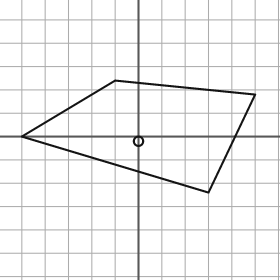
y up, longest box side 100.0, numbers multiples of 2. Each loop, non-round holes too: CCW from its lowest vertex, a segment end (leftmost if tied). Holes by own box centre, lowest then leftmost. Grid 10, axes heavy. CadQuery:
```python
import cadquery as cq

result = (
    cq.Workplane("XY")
    .moveTo(30.0, -24.0)
    .lineTo(50.0, 18.0)
    .lineTo(-10.0, 24.0)
    .lineTo(-50.0, 0.0)
    .close()
    .moveTo(0.0, -2.0)
    .circle(2.0)
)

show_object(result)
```